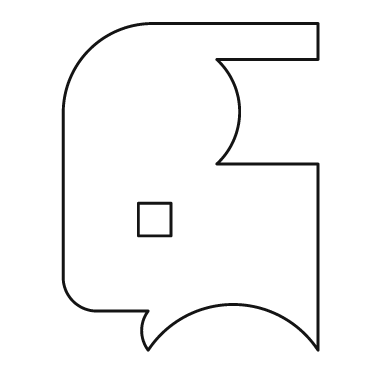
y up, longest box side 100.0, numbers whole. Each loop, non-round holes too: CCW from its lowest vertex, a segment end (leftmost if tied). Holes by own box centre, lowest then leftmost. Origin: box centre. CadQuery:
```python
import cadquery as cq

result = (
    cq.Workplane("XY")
    .moveTo(-13.0, -50.0)
    .threePointArc((13.0, -36.0), (39.0, -50.0))
    .lineTo(39.0, 7.0)
    .lineTo(8.0, 7.0)
    .threePointArc((15.0, 23.0), (8.0, 39.0))
    .lineTo(39.0, 39.0)
    .lineTo(39.0, 50.0)
    .lineTo(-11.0, 50.0)
    .threePointArc((-31.0, 42.0), (-39.0, 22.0))
    .lineTo(-39.0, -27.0)
    .threePointArc((-36.0, -35.0), (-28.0, -38.0))
    .lineTo(-13.0, -38.0)
    .threePointArc((-15.0, -44.0), (-13.0, -50.0))
    .close()
    .moveTo(-16.0, -15.0)
    .lineTo(-6.0, -15.0)
    .lineTo(-6.0, -5.0)
    .lineTo(-16.0, -5.0)
    .close()
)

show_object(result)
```